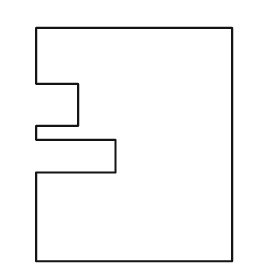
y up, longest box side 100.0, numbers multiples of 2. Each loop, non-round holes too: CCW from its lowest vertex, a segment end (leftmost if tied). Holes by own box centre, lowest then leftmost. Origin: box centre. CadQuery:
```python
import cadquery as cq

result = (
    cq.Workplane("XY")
    .moveTo(-42.0, -50.0)
    .lineTo(42.0, -50.0)
    .lineTo(42.0, 50.0)
    .lineTo(-42.0, 50.0)
    .lineTo(-42.0, 26.0)
    .lineTo(-24.0, 26.0)
    .lineTo(-24.0, 8.0)
    .lineTo(-42.0, 8.0)
    .lineTo(-42.0, 2.0)
    .lineTo(-8.0, 2.0)
    .lineTo(-8.0, -12.0)
    .lineTo(-42.0, -12.0)
    .close()
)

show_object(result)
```